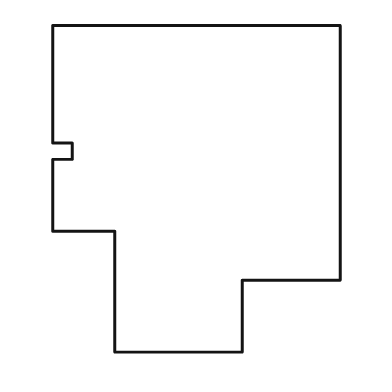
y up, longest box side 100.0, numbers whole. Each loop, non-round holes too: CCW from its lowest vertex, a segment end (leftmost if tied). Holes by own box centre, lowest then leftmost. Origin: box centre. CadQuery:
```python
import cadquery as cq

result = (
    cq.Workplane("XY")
    .moveTo(-25.0, -50.0)
    .lineTo(14.0, -50.0)
    .lineTo(14.0, -28.0)
    .lineTo(44.0, -28.0)
    .lineTo(44.0, 50.0)
    .lineTo(-44.0, 50.0)
    .lineTo(-44.0, 14.0)
    .lineTo(-38.0, 14.0)
    .lineTo(-38.0, 9.0)
    .lineTo(-44.0, 9.0)
    .lineTo(-44.0, -13.0)
    .lineTo(-25.0, -13.0)
    .close()
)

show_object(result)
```